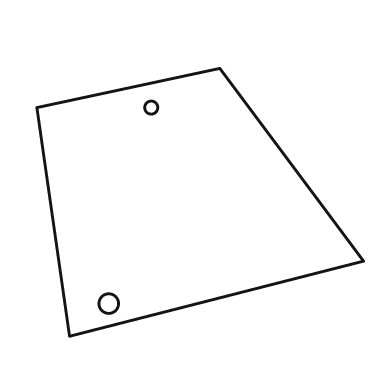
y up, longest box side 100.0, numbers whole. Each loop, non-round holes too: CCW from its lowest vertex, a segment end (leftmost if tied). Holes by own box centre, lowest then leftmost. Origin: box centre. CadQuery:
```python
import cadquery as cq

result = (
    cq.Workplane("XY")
    .moveTo(-40.0, -41.0)
    .lineTo(50.0, -18.0)
    .lineTo(6.0, 41.0)
    .lineTo(-50.0, 29.0)
    .close()
    .moveTo(-28.0, -31.0)
    .circle(3.0)
    .moveTo(-15.0, 29.0)
    .circle(2.0)
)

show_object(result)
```